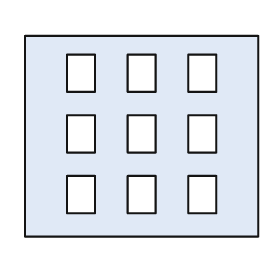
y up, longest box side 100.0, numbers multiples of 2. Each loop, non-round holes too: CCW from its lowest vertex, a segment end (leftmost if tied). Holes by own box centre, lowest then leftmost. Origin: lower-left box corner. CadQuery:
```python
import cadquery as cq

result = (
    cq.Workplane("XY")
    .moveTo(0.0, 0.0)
    .lineTo(100.0, 0.0)
    .lineTo(100.0, 86.0)
    .lineTo(0.0, 86.0)
    .close()
    .moveTo(18.0, 10.0)
    .lineTo(30.0, 10.0)
    .lineTo(30.0, 26.0)
    .lineTo(18.0, 26.0)
    .close()
    .moveTo(44.0, 10.0)
    .lineTo(56.0, 10.0)
    .lineTo(56.0, 26.0)
    .lineTo(44.0, 26.0)
    .close()
    .moveTo(70.0, 10.0)
    .lineTo(82.0, 10.0)
    .lineTo(82.0, 26.0)
    .lineTo(70.0, 26.0)
    .close()
    .moveTo(18.0, 36.0)
    .lineTo(30.0, 36.0)
    .lineTo(30.0, 52.0)
    .lineTo(18.0, 52.0)
    .close()
    .moveTo(44.0, 36.0)
    .lineTo(56.0, 36.0)
    .lineTo(56.0, 52.0)
    .lineTo(44.0, 52.0)
    .close()
    .moveTo(70.0, 36.0)
    .lineTo(82.0, 36.0)
    .lineTo(82.0, 52.0)
    .lineTo(70.0, 52.0)
    .close()
    .moveTo(18.0, 62.0)
    .lineTo(30.0, 62.0)
    .lineTo(30.0, 78.0)
    .lineTo(18.0, 78.0)
    .close()
    .moveTo(44.0, 62.0)
    .lineTo(56.0, 62.0)
    .lineTo(56.0, 78.0)
    .lineTo(44.0, 78.0)
    .close()
    .moveTo(70.0, 62.0)
    .lineTo(82.0, 62.0)
    .lineTo(82.0, 78.0)
    .lineTo(70.0, 78.0)
    .close()
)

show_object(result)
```